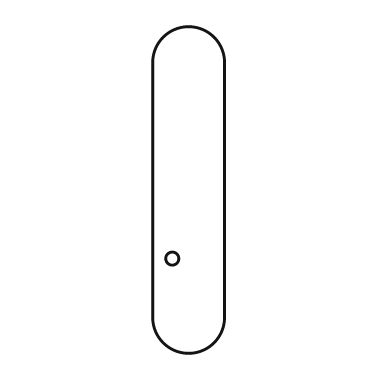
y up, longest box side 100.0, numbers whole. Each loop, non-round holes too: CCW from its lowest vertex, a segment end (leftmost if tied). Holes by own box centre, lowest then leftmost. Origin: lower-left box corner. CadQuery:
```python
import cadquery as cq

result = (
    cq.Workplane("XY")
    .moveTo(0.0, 11.0)
    .threePointArc((11.0, 0.0), (22.0, 11.0))
    .lineTo(22.0, 89.0)
    .threePointArc((11.0, 100.0), (0.0, 89.0))
    .close()
    .moveTo(6.0, 29.0)
    .circle(2.0)
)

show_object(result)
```